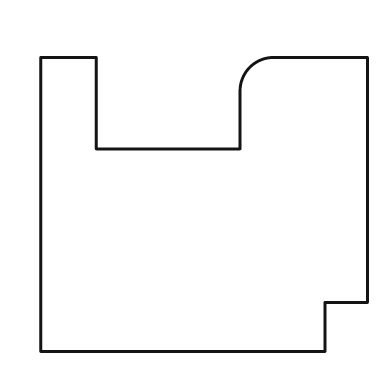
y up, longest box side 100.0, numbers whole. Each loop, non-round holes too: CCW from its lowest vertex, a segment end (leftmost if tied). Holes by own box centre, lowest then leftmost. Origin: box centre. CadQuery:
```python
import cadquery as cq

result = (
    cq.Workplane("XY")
    .moveTo(-50.0, -45.0)
    .lineTo(37.0, -45.0)
    .lineTo(37.0, -30.0)
    .lineTo(50.0, -30.0)
    .lineTo(50.0, 45.0)
    .lineTo(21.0, 45.0)
    .threePointArc((14.0, 42.0), (11.0, 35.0))
    .lineTo(11.0, 17.0)
    .lineTo(-33.0, 17.0)
    .lineTo(-33.0, 45.0)
    .lineTo(-50.0, 45.0)
    .close()
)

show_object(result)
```